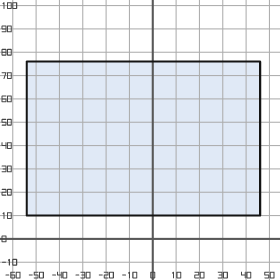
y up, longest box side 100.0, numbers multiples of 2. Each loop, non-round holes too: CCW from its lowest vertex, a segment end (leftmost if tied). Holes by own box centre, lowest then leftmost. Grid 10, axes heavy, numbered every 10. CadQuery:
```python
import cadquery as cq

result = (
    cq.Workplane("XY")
    .moveTo(-54.0, 10.0)
    .lineTo(46.0, 10.0)
    .lineTo(46.0, 76.0)
    .lineTo(-54.0, 76.0)
    .close()
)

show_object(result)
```